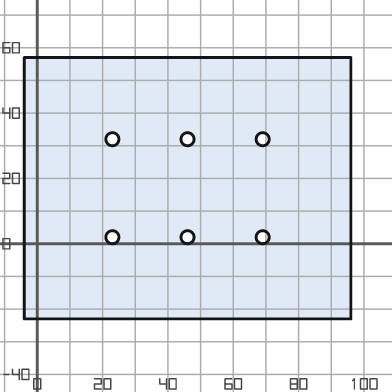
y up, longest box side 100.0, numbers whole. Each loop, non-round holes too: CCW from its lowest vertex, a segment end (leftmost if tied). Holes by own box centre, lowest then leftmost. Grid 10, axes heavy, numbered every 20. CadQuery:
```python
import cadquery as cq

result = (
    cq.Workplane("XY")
    .moveTo(-4.0, -23.0)
    .lineTo(96.0, -23.0)
    .lineTo(96.0, 57.0)
    .lineTo(-4.0, 57.0)
    .close()
    .moveTo(23.0, 2.0)
    .circle(2.0)
    .moveTo(46.0, 2.0)
    .circle(2.0)
    .moveTo(69.0, 2.0)
    .circle(2.0)
    .moveTo(23.0, 32.0)
    .circle(2.0)
    .moveTo(46.0, 32.0)
    .circle(2.0)
    .moveTo(69.0, 32.0)
    .circle(2.0)
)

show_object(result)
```